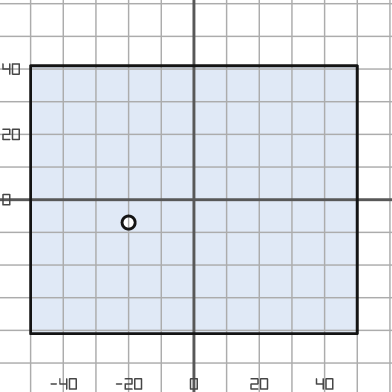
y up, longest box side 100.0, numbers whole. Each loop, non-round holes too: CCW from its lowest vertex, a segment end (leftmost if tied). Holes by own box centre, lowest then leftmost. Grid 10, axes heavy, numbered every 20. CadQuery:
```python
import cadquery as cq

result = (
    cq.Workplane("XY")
    .moveTo(-50.0, -41.0)
    .lineTo(50.0, -41.0)
    .lineTo(50.0, 41.0)
    .lineTo(-50.0, 41.0)
    .close()
    .moveTo(-20.0, -7.0)
    .circle(2.0)
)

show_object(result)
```